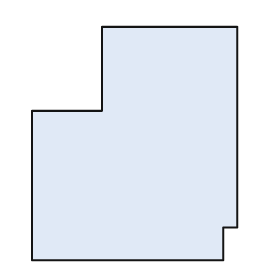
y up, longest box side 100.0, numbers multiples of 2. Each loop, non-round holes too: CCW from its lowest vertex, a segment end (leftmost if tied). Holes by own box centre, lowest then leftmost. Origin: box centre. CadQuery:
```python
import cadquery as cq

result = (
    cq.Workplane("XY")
    .moveTo(-44.0, -50.0)
    .lineTo(38.0, -50.0)
    .lineTo(38.0, -36.0)
    .lineTo(44.0, -36.0)
    .lineTo(44.0, 50.0)
    .lineTo(-14.0, 50.0)
    .lineTo(-14.0, 14.0)
    .lineTo(-44.0, 14.0)
    .close()
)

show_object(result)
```